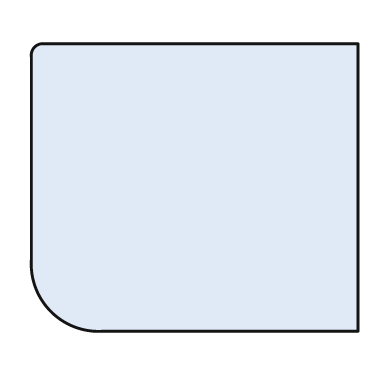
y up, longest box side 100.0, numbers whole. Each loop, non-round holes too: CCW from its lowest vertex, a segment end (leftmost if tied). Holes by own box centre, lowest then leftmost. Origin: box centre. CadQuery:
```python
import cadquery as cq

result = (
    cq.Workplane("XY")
    .moveTo(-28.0, -44.0)
    .lineTo(50.0, -44.0)
    .lineTo(50.0, 44.0)
    .lineTo(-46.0, 44.0)
    .threePointArc((-49.0, 43.0), (-50.0, 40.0))
    .lineTo(-50.0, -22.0)
    .threePointArc((-44.0, -38.0), (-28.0, -44.0))
    .close()
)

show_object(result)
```